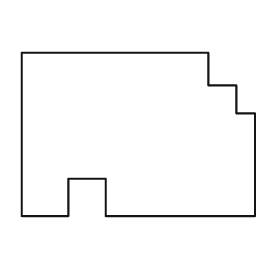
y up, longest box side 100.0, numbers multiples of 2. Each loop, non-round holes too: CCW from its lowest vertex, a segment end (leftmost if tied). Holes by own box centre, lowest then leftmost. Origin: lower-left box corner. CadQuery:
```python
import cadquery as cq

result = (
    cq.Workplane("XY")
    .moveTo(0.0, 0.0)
    .lineTo(20.0, 0.0)
    .lineTo(20.0, 16.0)
    .lineTo(36.0, 16.0)
    .lineTo(36.0, 0.0)
    .lineTo(100.0, 0.0)
    .lineTo(100.0, 44.0)
    .lineTo(92.0, 44.0)
    .lineTo(92.0, 56.0)
    .lineTo(80.0, 56.0)
    .lineTo(80.0, 70.0)
    .lineTo(0.0, 70.0)
    .close()
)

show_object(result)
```